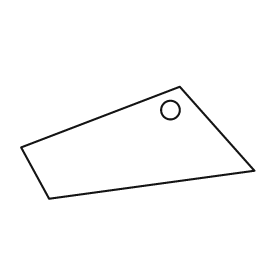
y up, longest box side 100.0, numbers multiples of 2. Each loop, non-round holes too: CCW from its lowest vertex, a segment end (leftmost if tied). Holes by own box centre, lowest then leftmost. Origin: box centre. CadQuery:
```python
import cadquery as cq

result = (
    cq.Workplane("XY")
    .moveTo(-38.0, -24.0)
    .lineTo(50.0, -12.0)
    .lineTo(18.0, 24.0)
    .lineTo(-50.0, -2.0)
    .close()
    .moveTo(14.0, 14.0)
    .circle(4.0)
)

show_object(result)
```